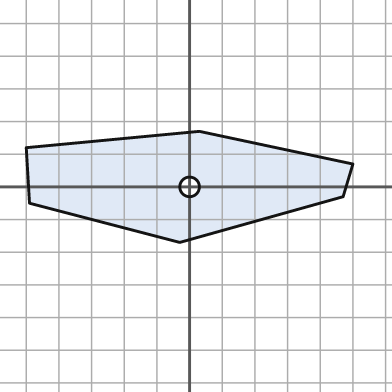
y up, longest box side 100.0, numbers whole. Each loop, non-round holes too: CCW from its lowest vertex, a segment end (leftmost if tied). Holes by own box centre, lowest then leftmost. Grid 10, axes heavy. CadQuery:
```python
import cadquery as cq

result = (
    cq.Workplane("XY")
    .moveTo(-3.0, -17.0)
    .lineTo(47.0, -3.0)
    .lineTo(50.0, 7.0)
    .lineTo(3.0, 17.0)
    .lineTo(-50.0, 12.0)
    .lineTo(-49.0, -5.0)
    .close()
    .moveTo(0.0, 0.0)
    .circle(3.0)
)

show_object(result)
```